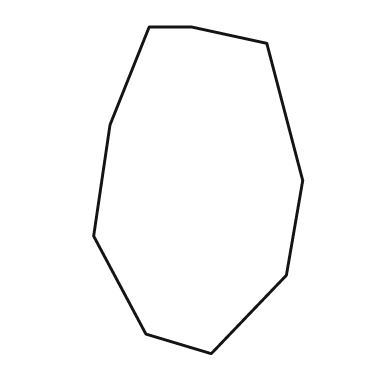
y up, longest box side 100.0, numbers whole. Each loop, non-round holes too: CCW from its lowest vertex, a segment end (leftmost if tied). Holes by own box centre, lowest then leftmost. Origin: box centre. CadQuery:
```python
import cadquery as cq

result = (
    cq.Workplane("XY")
    .moveTo(4.0, -50.0)
    .lineTo(27.0, -26.0)
    .lineTo(32.0, 3.0)
    .lineTo(21.0, 45.0)
    .lineTo(-2.0, 50.0)
    .lineTo(-15.0, 50.0)
    .lineTo(-27.0, 20.0)
    .lineTo(-32.0, -14.0)
    .lineTo(-16.0, -44.0)
    .close()
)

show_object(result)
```